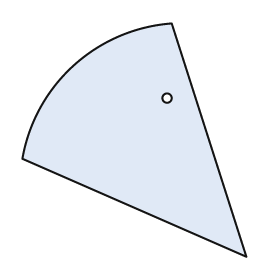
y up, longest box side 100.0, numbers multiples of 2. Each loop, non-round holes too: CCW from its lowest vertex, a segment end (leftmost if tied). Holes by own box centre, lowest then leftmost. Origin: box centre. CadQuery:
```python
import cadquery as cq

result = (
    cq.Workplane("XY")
    .moveTo(48.0, -50.0)
    .lineTo(16.0, 50.0)
    .threePointArc((-26.0, 32.0), (-48.0, -8.0))
    .close()
    .moveTo(14.0, 18.0)
    .circle(2.0)
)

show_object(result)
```